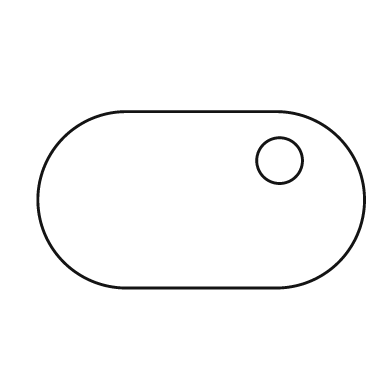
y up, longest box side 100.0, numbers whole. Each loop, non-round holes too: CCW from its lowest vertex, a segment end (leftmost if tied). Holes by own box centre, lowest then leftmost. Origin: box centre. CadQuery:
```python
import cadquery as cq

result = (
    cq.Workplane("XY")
    .moveTo(-23.0, -27.0)
    .lineTo(23.0, -27.0)
    .threePointArc((50.0, 0.0), (23.0, 27.0))
    .lineTo(-23.0, 27.0)
    .threePointArc((-50.0, 0.0), (-23.0, -27.0))
    .close()
    .moveTo(24.0, 12.0)
    .circle(7.0)
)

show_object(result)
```